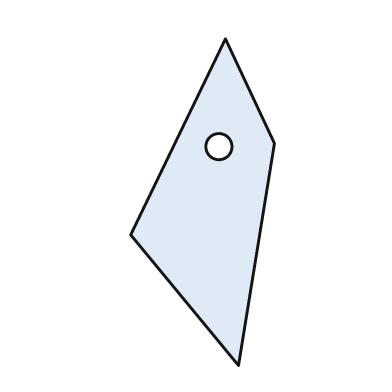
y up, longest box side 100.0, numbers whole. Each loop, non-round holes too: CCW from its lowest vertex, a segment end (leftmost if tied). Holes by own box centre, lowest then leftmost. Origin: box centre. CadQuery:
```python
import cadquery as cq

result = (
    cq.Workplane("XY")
    .moveTo(11.0, -50.0)
    .lineTo(22.0, 18.0)
    .lineTo(7.0, 50.0)
    .lineTo(-22.0, -10.0)
    .close()
    .moveTo(5.0, 17.0)
    .circle(4.0)
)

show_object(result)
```